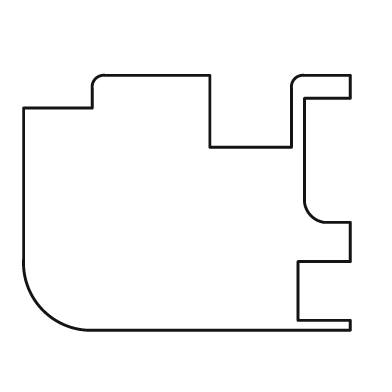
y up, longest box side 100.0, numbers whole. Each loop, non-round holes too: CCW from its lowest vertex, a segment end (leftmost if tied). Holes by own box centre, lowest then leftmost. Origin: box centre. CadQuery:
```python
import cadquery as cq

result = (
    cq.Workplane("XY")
    .moveTo(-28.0, -39.0)
    .lineTo(50.0, -39.0)
    .lineTo(50.0, -36.0)
    .lineTo(34.0, -36.0)
    .lineTo(34.0, -18.0)
    .lineTo(50.0, -18.0)
    .lineTo(50.0, -6.0)
    .lineTo(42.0, -6.0)
    .threePointArc((38.0, -4.0), (36.0, 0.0))
    .lineTo(36.0, 32.0)
    .lineTo(50.0, 32.0)
    .lineTo(50.0, 39.0)
    .lineTo(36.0, 39.0)
    .threePointArc((33.0, 38.0), (32.0, 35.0))
    .lineTo(32.0, 17.0)
    .lineTo(7.0, 17.0)
    .lineTo(7.0, 39.0)
    .lineTo(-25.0, 39.0)
    .threePointArc((-28.0, 38.0), (-29.0, 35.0))
    .lineTo(-29.0, 29.0)
    .lineTo(-50.0, 29.0)
    .lineTo(-50.0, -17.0)
    .threePointArc((-44.0, -33.0), (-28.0, -39.0))
    .close()
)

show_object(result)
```